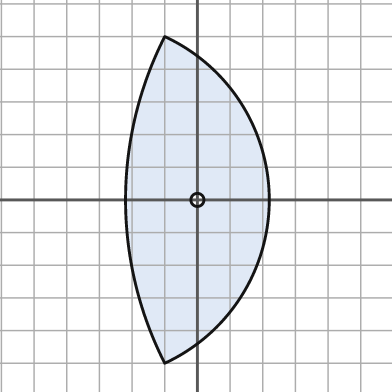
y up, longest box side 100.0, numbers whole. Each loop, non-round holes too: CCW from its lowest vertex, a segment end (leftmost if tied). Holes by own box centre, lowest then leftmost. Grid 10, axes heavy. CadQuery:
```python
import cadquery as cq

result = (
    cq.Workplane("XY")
    .moveTo(-10.0, -50.0)
    .threePointArc((22.0, 0.0), (-10.0, 50.0))
    .threePointArc((-22.0, 0.0), (-10.0, -50.0))
    .close()
    .moveTo(0.0, 0.0)
    .circle(2.0)
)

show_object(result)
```